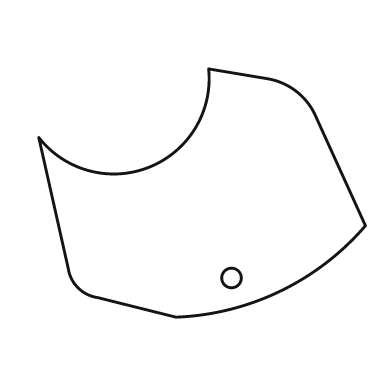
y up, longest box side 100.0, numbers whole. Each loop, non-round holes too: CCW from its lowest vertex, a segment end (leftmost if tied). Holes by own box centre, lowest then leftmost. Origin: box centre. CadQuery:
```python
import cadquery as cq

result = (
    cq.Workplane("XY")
    .moveTo(-8.0, -38.0)
    .threePointArc((24.0, -30.0), (50.0, -10.0))
    .lineTo(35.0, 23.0)
    .threePointArc((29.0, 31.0), (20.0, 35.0))
    .lineTo(2.0, 38.0)
    .threePointArc((-16.0, 8.0), (-50.0, 17.0))
    .lineTo(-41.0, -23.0)
    .threePointArc((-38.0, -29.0), (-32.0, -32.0))
    .close()
    .moveTo(9.0, -26.0)
    .circle(3.0)
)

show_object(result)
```